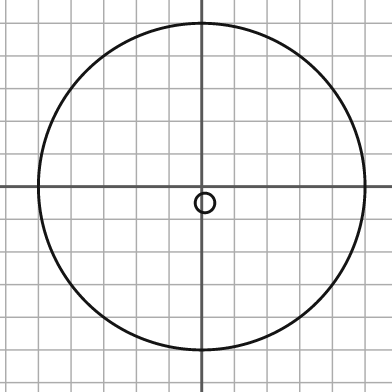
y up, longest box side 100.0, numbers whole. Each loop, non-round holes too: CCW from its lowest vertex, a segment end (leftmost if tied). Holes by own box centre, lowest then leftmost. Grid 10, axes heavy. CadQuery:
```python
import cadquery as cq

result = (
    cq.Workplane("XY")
    .moveTo(0.0, 0.0)
    .circle(50.0)
    .moveTo(1.0, -5.0)
    .circle(3.0)
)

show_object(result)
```